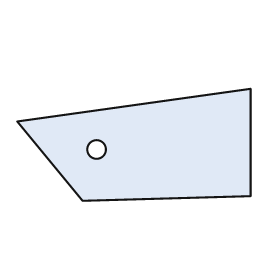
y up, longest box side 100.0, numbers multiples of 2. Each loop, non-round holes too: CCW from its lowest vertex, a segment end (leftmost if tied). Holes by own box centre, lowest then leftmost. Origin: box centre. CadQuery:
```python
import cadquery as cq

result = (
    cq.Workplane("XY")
    .moveTo(-22.0, -24.0)
    .lineTo(50.0, -22.0)
    .lineTo(50.0, 24.0)
    .lineTo(-50.0, 10.0)
    .close()
    .moveTo(-16.0, -2.0)
    .circle(4.0)
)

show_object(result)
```